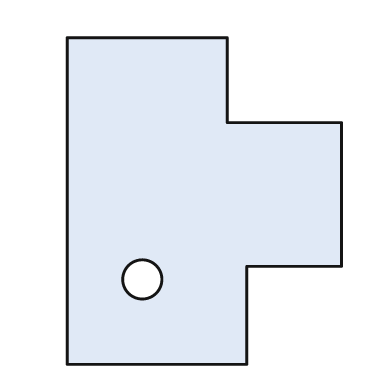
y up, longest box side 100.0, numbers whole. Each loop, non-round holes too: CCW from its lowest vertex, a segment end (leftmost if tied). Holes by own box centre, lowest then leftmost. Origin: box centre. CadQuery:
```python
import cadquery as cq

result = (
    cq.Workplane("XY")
    .moveTo(-42.0, -50.0)
    .lineTo(13.0, -50.0)
    .lineTo(13.0, -20.0)
    .lineTo(42.0, -20.0)
    .lineTo(42.0, 24.0)
    .lineTo(7.0, 24.0)
    .lineTo(7.0, 50.0)
    .lineTo(-42.0, 50.0)
    .close()
    .moveTo(-19.0, -24.0)
    .circle(6.0)
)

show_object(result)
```